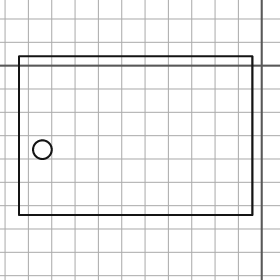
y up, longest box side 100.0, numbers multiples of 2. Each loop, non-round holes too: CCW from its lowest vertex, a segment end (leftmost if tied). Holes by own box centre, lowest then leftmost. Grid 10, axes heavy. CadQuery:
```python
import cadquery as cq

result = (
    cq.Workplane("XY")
    .moveTo(-104.0, -64.0)
    .lineTo(-4.0, -64.0)
    .lineTo(-4.0, 4.0)
    .lineTo(-104.0, 4.0)
    .close()
    .moveTo(-94.0, -36.0)
    .circle(4.0)
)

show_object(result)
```